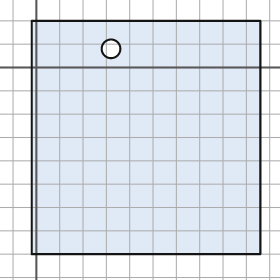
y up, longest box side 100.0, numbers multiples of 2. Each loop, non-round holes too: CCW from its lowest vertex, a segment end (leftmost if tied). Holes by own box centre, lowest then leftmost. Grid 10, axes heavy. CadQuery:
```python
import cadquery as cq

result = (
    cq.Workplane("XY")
    .moveTo(-2.0, -80.0)
    .lineTo(96.0, -80.0)
    .lineTo(96.0, 20.0)
    .lineTo(-2.0, 20.0)
    .close()
    .moveTo(32.0, 8.0)
    .circle(4.0)
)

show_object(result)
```